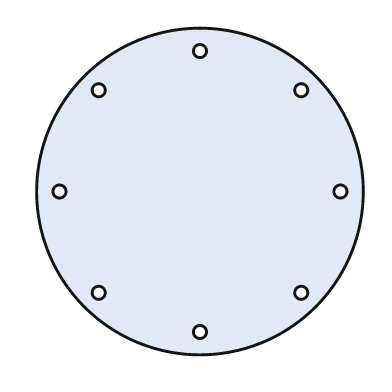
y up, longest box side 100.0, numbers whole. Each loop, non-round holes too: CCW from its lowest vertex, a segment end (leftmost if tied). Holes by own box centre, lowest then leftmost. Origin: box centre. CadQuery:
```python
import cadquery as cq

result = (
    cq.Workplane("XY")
    .moveTo(0.0, 0.0)
    .circle(50.0)
    .moveTo(0.0, -43.0)
    .circle(2.0)
    .moveTo(-31.0, -31.0)
    .circle(2.0)
    .moveTo(31.0, -31.0)
    .circle(2.0)
    .moveTo(-43.0, 0.0)
    .circle(2.0)
    .moveTo(43.0, 0.0)
    .circle(2.0)
    .moveTo(-31.0, 31.0)
    .circle(2.0)
    .moveTo(31.0, 31.0)
    .circle(2.0)
    .moveTo(0.0, 43.0)
    .circle(2.0)
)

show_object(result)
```